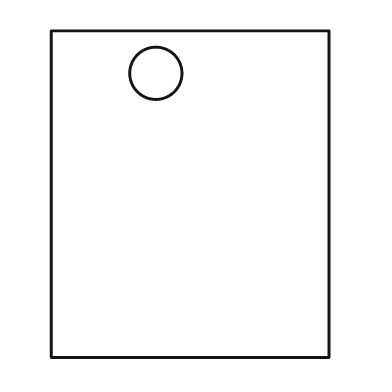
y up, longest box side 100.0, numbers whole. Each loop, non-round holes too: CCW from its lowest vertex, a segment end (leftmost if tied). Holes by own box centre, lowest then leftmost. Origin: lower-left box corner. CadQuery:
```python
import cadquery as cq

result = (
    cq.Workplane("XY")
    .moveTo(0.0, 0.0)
    .lineTo(85.0, 0.0)
    .lineTo(85.0, 100.0)
    .lineTo(0.0, 100.0)
    .close()
    .moveTo(32.0, 87.0)
    .circle(8.0)
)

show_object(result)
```